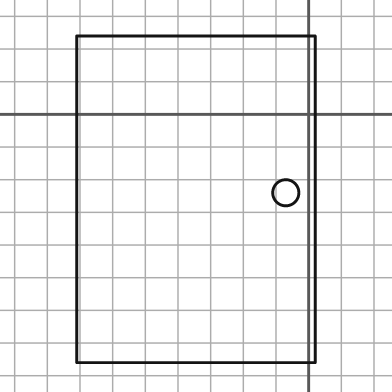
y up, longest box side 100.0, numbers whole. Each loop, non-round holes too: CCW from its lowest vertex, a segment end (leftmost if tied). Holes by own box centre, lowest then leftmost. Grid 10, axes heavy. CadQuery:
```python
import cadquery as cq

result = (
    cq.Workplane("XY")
    .moveTo(-71.0, -76.0)
    .lineTo(2.0, -76.0)
    .lineTo(2.0, 24.0)
    .lineTo(-71.0, 24.0)
    .close()
    .moveTo(-7.0, -24.0)
    .circle(4.0)
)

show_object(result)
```